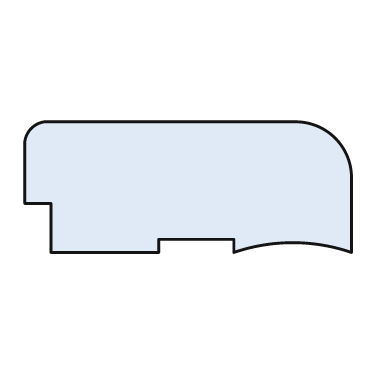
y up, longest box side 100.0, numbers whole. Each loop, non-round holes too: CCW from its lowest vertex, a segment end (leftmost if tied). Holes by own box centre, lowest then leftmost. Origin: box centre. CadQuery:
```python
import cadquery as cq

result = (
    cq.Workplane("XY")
    .moveTo(-42.0, -20.0)
    .lineTo(-9.0, -20.0)
    .lineTo(-9.0, -16.0)
    .lineTo(14.0, -16.0)
    .lineTo(14.0, -20.0)
    .threePointArc((32.0, -17.0), (50.0, -20.0))
    .lineTo(50.0, 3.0)
    .threePointArc((45.0, 15.0), (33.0, 20.0))
    .lineTo(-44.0, 20.0)
    .threePointArc((-48.0, 18.0), (-50.0, 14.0))
    .lineTo(-50.0, -5.0)
    .lineTo(-42.0, -5.0)
    .close()
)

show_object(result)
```